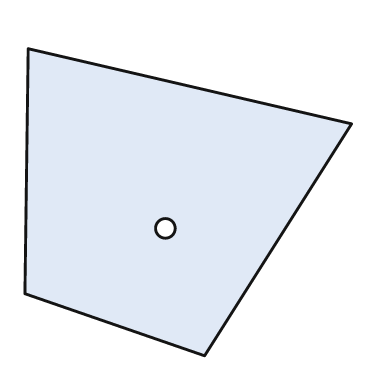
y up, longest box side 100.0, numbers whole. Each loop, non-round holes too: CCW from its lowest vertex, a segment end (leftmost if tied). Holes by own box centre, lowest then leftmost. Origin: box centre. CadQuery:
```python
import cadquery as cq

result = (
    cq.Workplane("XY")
    .moveTo(5.0, -47.0)
    .lineTo(50.0, 24.0)
    .lineTo(-49.0, 47.0)
    .lineTo(-50.0, -28.0)
    .close()
    .moveTo(-7.0, -8.0)
    .circle(3.0)
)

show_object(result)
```